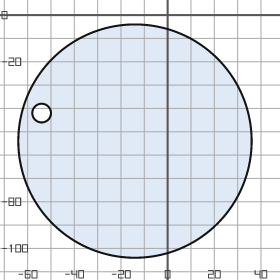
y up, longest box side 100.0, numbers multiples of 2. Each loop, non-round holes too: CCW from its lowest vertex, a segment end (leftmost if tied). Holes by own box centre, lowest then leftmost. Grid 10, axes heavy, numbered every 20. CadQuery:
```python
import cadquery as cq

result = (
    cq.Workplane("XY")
    .moveTo(-14.0, -54.0)
    .circle(50.0)
    .moveTo(-54.0, -42.0)
    .circle(4.0)
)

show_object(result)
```